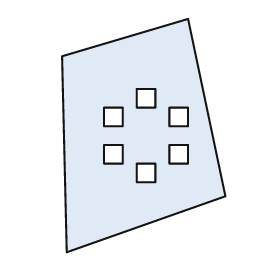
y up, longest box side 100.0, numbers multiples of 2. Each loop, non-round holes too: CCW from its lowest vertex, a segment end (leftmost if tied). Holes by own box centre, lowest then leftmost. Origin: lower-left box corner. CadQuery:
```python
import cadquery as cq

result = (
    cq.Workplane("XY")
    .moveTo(2.0, 0.0)
    .lineTo(70.0, 24.0)
    .lineTo(54.0, 100.0)
    .lineTo(0.0, 84.0)
    .close()
    .moveTo(32.0, 30.0)
    .lineTo(40.0, 30.0)
    .lineTo(40.0, 38.0)
    .lineTo(32.0, 38.0)
    .close()
    .moveTo(18.0, 38.0)
    .lineTo(26.0, 38.0)
    .lineTo(26.0, 46.0)
    .lineTo(18.0, 46.0)
    .close()
    .moveTo(46.0, 38.0)
    .lineTo(54.0, 38.0)
    .lineTo(54.0, 46.0)
    .lineTo(46.0, 46.0)
    .close()
    .moveTo(18.0, 54.0)
    .lineTo(26.0, 54.0)
    .lineTo(26.0, 62.0)
    .lineTo(18.0, 62.0)
    .close()
    .moveTo(46.0, 54.0)
    .lineTo(54.0, 54.0)
    .lineTo(54.0, 62.0)
    .lineTo(46.0, 62.0)
    .close()
    .moveTo(32.0, 62.0)
    .lineTo(40.0, 62.0)
    .lineTo(40.0, 70.0)
    .lineTo(32.0, 70.0)
    .close()
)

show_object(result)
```